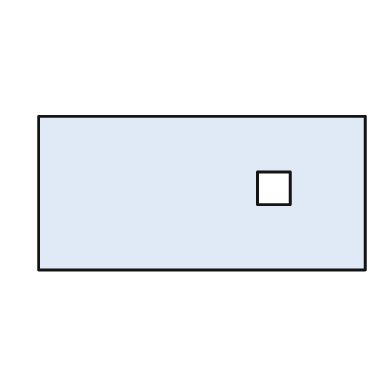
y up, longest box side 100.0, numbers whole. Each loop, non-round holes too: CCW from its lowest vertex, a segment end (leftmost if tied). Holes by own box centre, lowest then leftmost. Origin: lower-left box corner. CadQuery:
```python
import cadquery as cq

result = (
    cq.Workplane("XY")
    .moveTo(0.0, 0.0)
    .lineTo(100.0, 0.0)
    .lineTo(100.0, 47.0)
    .lineTo(0.0, 47.0)
    .close()
    .moveTo(67.0, 20.0)
    .lineTo(77.0, 20.0)
    .lineTo(77.0, 30.0)
    .lineTo(67.0, 30.0)
    .close()
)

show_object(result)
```